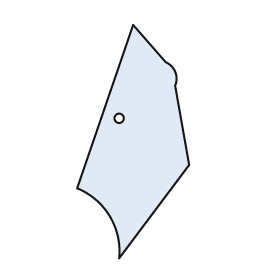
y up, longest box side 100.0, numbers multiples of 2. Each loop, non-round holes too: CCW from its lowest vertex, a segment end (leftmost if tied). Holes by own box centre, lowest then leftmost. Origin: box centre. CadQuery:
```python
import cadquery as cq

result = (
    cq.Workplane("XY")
    .moveTo(-6.0, -50.0)
    .lineTo(24.0, -10.0)
    .lineTo(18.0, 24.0)
    .threePointArc((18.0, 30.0), (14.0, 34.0))
    .lineTo(0.0, 50.0)
    .lineTo(-24.0, -20.0)
    .threePointArc((-10.0, -32.0), (-6.0, -50.0))
    .close()
    .moveTo(-6.0, 10.0)
    .circle(2.0)
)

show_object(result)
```